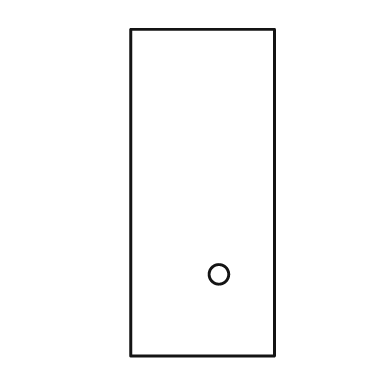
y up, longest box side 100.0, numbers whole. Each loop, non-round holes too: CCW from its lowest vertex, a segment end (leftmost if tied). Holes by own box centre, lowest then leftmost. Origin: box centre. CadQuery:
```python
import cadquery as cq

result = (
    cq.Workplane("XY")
    .moveTo(-22.0, -50.0)
    .lineTo(22.0, -50.0)
    .lineTo(22.0, 50.0)
    .lineTo(-22.0, 50.0)
    .close()
    .moveTo(5.0, -25.0)
    .circle(3.0)
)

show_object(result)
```